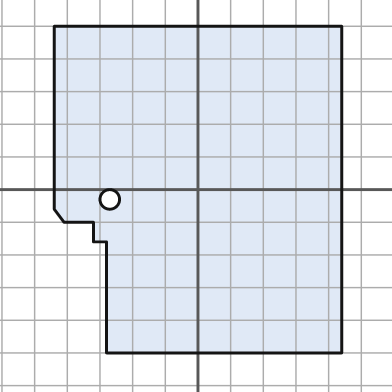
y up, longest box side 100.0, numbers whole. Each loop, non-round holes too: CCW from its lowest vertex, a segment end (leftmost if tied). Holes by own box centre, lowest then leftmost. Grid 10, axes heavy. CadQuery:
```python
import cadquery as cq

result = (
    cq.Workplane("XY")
    .moveTo(-28.0, -50.0)
    .lineTo(44.0, -50.0)
    .lineTo(44.0, 50.0)
    .lineTo(-44.0, 50.0)
    .lineTo(-44.0, -6.0)
    .lineTo(-41.0, -10.0)
    .lineTo(-32.0, -10.0)
    .lineTo(-32.0, -16.0)
    .lineTo(-28.0, -16.0)
    .close()
    .moveTo(-27.0, -3.0)
    .circle(3.0)
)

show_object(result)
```